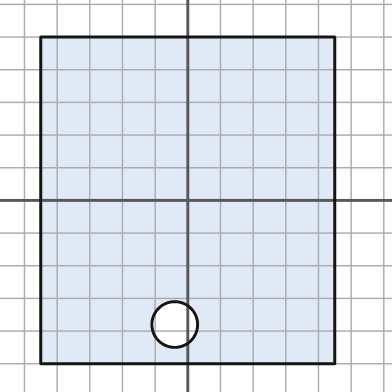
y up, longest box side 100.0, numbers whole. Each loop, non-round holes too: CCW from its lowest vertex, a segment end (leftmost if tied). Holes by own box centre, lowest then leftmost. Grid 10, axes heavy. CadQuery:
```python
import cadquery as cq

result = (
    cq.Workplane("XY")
    .moveTo(-45.0, -50.0)
    .lineTo(45.0, -50.0)
    .lineTo(45.0, 50.0)
    .lineTo(-45.0, 50.0)
    .close()
    .moveTo(-4.0, -38.0)
    .circle(7.0)
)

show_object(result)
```